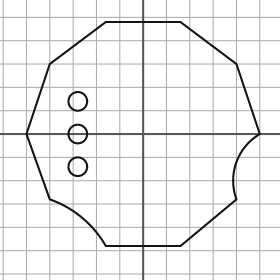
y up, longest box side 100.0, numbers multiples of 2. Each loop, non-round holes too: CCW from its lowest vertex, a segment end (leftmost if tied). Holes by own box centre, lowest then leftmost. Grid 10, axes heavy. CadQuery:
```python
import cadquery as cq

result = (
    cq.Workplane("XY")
    .moveTo(-16.0, -48.0)
    .lineTo(16.0, -48.0)
    .lineTo(40.0, -28.0)
    .threePointArc((40.0, -12.0), (50.0, 0.0))
    .lineTo(40.0, 30.0)
    .lineTo(16.0, 48.0)
    .lineTo(-16.0, 48.0)
    .lineTo(-40.0, 30.0)
    .lineTo(-50.0, 0.0)
    .lineTo(-40.0, -28.0)
    .threePointArc((-26.0, -36.0), (-16.0, -48.0))
    .close()
    .moveTo(-28.0, -14.0)
    .circle(4.0)
    .moveTo(-28.0, 0.0)
    .circle(4.0)
    .moveTo(-28.0, 14.0)
    .circle(4.0)
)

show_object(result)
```